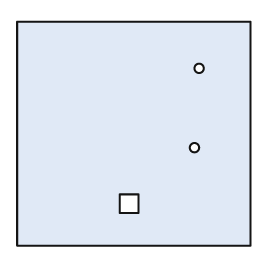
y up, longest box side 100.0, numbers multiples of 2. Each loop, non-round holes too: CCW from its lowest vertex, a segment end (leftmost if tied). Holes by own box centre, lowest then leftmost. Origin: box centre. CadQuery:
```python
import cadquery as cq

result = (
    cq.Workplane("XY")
    .moveTo(-50.0, -48.0)
    .lineTo(50.0, -48.0)
    .lineTo(50.0, 48.0)
    .lineTo(-50.0, 48.0)
    .close()
    .moveTo(-6.0, -34.0)
    .lineTo(2.0, -34.0)
    .lineTo(2.0, -26.0)
    .lineTo(-6.0, -26.0)
    .close()
    .moveTo(26.0, -6.0)
    .circle(2.0)
    .moveTo(28.0, 28.0)
    .circle(2.0)
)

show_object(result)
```